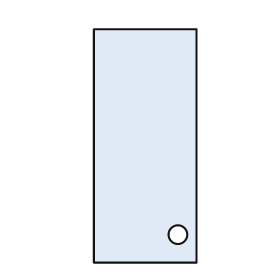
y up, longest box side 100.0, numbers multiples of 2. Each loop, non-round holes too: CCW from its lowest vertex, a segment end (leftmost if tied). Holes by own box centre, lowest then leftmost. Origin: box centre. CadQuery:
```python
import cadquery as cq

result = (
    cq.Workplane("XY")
    .moveTo(-22.0, -50.0)
    .lineTo(22.0, -50.0)
    .lineTo(22.0, 50.0)
    .lineTo(-22.0, 50.0)
    .close()
    .moveTo(14.0, -38.0)
    .circle(4.0)
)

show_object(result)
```